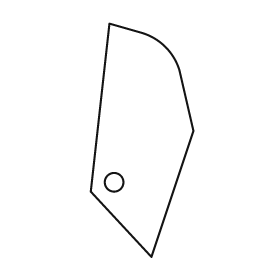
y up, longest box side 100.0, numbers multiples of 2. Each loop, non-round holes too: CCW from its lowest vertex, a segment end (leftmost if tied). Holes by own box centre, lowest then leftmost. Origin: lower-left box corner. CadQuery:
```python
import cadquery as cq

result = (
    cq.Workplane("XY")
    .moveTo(26.0, 0.0)
    .lineTo(44.0, 54.0)
    .lineTo(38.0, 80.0)
    .threePointArc((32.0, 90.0), (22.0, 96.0))
    .lineTo(8.0, 100.0)
    .lineTo(0.0, 28.0)
    .close()
    .moveTo(10.0, 32.0)
    .circle(4.0)
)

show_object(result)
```